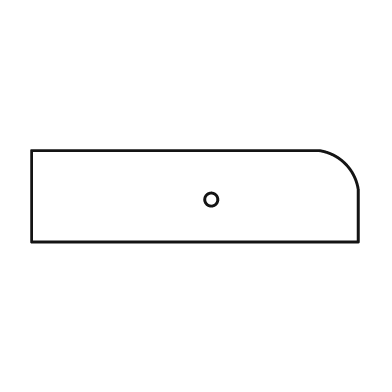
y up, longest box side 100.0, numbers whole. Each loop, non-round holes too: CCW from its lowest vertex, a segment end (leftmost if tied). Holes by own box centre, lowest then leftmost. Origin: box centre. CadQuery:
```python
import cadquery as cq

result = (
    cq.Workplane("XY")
    .moveTo(-50.0, -14.0)
    .lineTo(50.0, -14.0)
    .lineTo(50.0, 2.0)
    .threePointArc((46.0, 10.0), (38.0, 14.0))
    .lineTo(-50.0, 14.0)
    .close()
    .moveTo(5.0, -1.0)
    .circle(2.0)
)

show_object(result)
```